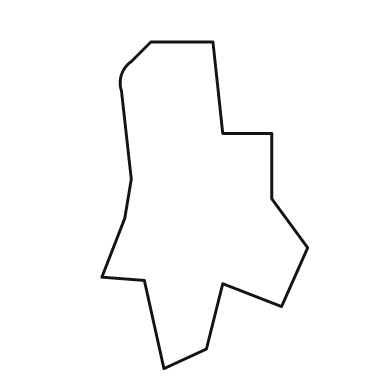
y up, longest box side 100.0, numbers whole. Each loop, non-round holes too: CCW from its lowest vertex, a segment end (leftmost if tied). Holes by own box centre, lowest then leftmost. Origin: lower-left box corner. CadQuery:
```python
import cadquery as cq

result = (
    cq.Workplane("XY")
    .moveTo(19.0, 0.0)
    .lineTo(32.0, 6.0)
    .lineTo(37.0, 26.0)
    .lineTo(55.0, 19.0)
    .lineTo(63.0, 37.0)
    .lineTo(52.0, 52.0)
    .lineTo(52.0, 72.0)
    .lineTo(37.0, 72.0)
    .lineTo(34.0, 100.0)
    .lineTo(15.0, 100.0)
    .lineTo(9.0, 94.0)
    .threePointArc((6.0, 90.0), (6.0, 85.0))
    .lineTo(9.0, 58.0)
    .lineTo(7.0, 46.0)
    .lineTo(0.0, 28.0)
    .lineTo(13.0, 27.0)
    .close()
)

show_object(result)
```